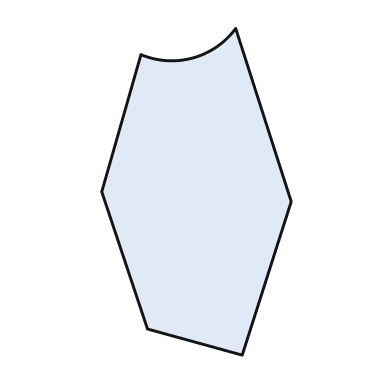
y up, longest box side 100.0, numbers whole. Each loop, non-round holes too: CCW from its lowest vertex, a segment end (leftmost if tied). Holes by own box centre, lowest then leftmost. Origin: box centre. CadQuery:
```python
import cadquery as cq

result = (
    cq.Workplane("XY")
    .moveTo(14.0, -50.0)
    .lineTo(29.0, -3.0)
    .lineTo(12.0, 50.0)
    .threePointArc((-1.0, 41.0), (-17.0, 42.0))
    .lineTo(-29.0, 0.0)
    .lineTo(-15.0, -42.0)
    .close()
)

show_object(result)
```